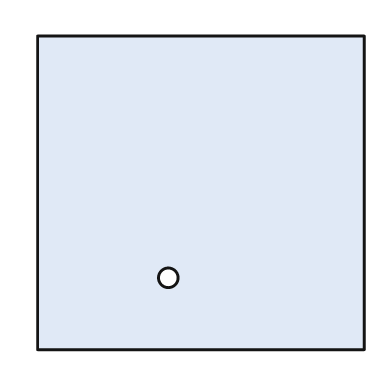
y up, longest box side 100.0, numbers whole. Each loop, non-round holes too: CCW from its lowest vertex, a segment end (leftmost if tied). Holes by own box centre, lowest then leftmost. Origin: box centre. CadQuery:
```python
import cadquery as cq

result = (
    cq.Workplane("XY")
    .moveTo(-50.0, -48.0)
    .lineTo(50.0, -48.0)
    .lineTo(50.0, 48.0)
    .lineTo(-50.0, 48.0)
    .close()
    .moveTo(-10.0, -26.0)
    .circle(3.0)
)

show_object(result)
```